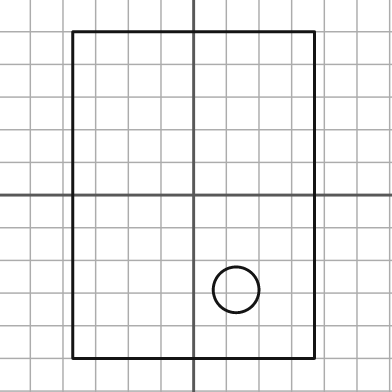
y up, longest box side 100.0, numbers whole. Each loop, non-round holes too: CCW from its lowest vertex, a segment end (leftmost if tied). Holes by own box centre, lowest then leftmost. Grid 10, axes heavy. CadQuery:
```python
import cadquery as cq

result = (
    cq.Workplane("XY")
    .moveTo(-37.0, -50.0)
    .lineTo(37.0, -50.0)
    .lineTo(37.0, 50.0)
    .lineTo(-37.0, 50.0)
    .close()
    .moveTo(13.0, -29.0)
    .circle(7.0)
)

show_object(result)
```